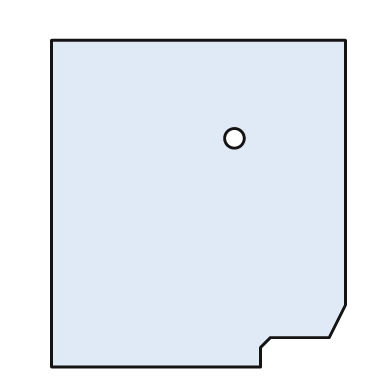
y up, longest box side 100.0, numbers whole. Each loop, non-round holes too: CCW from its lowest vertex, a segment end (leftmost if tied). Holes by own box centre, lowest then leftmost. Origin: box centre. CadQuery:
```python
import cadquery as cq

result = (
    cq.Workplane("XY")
    .moveTo(-45.0, -50.0)
    .lineTo(19.0, -50.0)
    .lineTo(19.0, -44.0)
    .lineTo(22.0, -41.0)
    .lineTo(40.0, -41.0)
    .lineTo(45.0, -31.0)
    .lineTo(45.0, 50.0)
    .lineTo(-45.0, 50.0)
    .close()
    .moveTo(11.0, 20.0)
    .circle(3.0)
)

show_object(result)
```